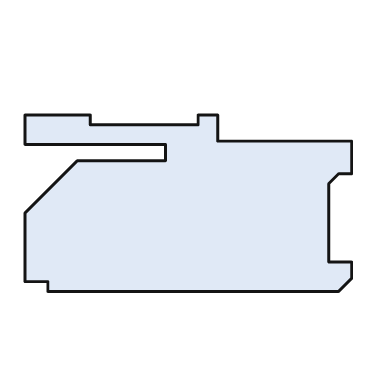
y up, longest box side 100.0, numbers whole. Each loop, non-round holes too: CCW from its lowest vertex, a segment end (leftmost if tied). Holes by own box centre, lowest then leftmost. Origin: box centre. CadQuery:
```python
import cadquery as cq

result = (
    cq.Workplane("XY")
    .moveTo(-43.0, -27.0)
    .lineTo(46.0, -27.0)
    .lineTo(50.0, -23.0)
    .lineTo(50.0, -18.0)
    .lineTo(43.0, -18.0)
    .lineTo(43.0, 6.0)
    .lineTo(46.0, 9.0)
    .lineTo(50.0, 9.0)
    .lineTo(50.0, 19.0)
    .lineTo(9.0, 19.0)
    .lineTo(9.0, 27.0)
    .lineTo(3.0, 27.0)
    .lineTo(3.0, 24.0)
    .lineTo(-30.0, 24.0)
    .lineTo(-30.0, 27.0)
    .lineTo(-50.0, 27.0)
    .lineTo(-50.0, 18.0)
    .lineTo(-7.0, 18.0)
    .lineTo(-7.0, 13.0)
    .lineTo(-34.0, 13.0)
    .lineTo(-50.0, -3.0)
    .lineTo(-50.0, -24.0)
    .lineTo(-43.0, -24.0)
    .close()
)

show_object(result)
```